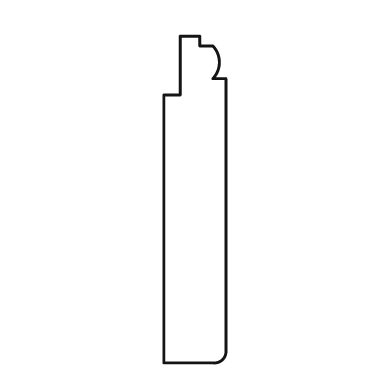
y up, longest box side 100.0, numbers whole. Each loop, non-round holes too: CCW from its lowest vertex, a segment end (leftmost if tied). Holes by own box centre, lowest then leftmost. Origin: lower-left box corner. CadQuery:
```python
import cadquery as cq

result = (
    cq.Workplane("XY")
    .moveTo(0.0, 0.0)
    .lineTo(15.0, 0.0)
    .threePointArc((18.0, 1.0), (19.0, 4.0))
    .lineTo(19.0, 87.0)
    .lineTo(15.0, 87.0)
    .threePointArc((17.0, 92.0), (15.0, 97.0))
    .lineTo(11.0, 97.0)
    .lineTo(11.0, 100.0)
    .lineTo(5.0, 100.0)
    .lineTo(5.0, 82.0)
    .lineTo(0.0, 82.0)
    .close()
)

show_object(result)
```